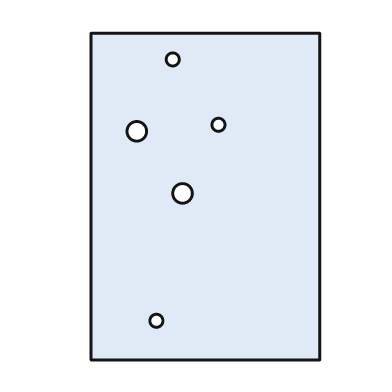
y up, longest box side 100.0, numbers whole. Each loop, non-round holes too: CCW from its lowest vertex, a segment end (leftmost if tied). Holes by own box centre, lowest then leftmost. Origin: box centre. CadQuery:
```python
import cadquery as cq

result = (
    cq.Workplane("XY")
    .moveTo(-35.0, -50.0)
    .lineTo(35.0, -50.0)
    .lineTo(35.0, 50.0)
    .lineTo(-35.0, 50.0)
    .close()
    .moveTo(-15.0, -38.0)
    .circle(2.0)
    .moveTo(-7.0, 1.0)
    .circle(3.0)
    .moveTo(-21.0, 20.0)
    .circle(3.0)
    .moveTo(4.0, 22.0)
    .circle(2.0)
    .moveTo(-10.0, 42.0)
    .circle(2.0)
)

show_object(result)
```